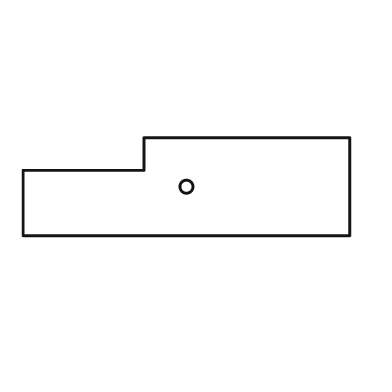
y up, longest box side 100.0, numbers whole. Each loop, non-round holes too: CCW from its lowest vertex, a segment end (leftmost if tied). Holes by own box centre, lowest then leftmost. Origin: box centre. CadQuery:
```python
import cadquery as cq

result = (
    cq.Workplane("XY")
    .moveTo(-50.0, -15.0)
    .lineTo(50.0, -15.0)
    .lineTo(50.0, 15.0)
    .lineTo(-13.0, 15.0)
    .lineTo(-13.0, 5.0)
    .lineTo(-50.0, 5.0)
    .close()
    .moveTo(0.0, 0.0)
    .circle(2.0)
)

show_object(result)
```